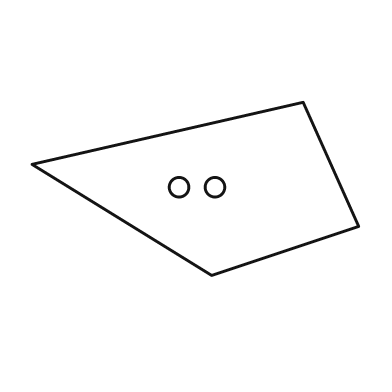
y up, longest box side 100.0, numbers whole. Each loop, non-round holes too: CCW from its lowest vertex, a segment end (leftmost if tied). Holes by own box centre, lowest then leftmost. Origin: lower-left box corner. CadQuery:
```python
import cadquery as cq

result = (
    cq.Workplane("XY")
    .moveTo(55.0, 0.0)
    .lineTo(100.0, 15.0)
    .lineTo(83.0, 53.0)
    .lineTo(0.0, 34.0)
    .close()
    .moveTo(45.0, 27.0)
    .circle(3.0)
    .moveTo(56.0, 27.0)
    .circle(3.0)
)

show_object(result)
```